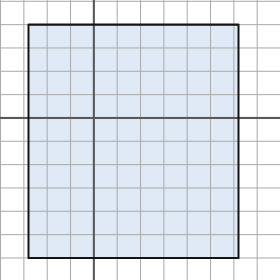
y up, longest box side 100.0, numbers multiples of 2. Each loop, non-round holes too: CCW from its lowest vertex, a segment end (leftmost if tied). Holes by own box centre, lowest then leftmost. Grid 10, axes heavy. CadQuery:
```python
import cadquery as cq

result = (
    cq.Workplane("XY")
    .moveTo(-28.0, -60.0)
    .lineTo(62.0, -60.0)
    .lineTo(62.0, 40.0)
    .lineTo(-28.0, 40.0)
    .close()
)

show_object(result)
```